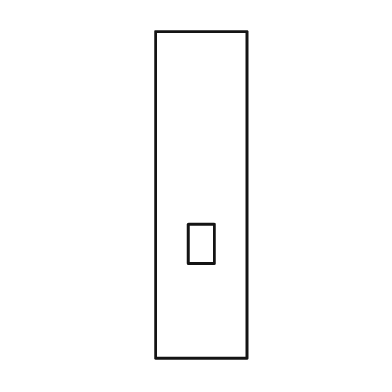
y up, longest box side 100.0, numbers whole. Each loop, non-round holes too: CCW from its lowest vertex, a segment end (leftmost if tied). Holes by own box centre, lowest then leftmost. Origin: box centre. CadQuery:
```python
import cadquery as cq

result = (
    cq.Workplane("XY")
    .moveTo(-14.0, -50.0)
    .lineTo(14.0, -50.0)
    .lineTo(14.0, 50.0)
    .lineTo(-14.0, 50.0)
    .close()
    .moveTo(-4.0, -21.0)
    .lineTo(4.0, -21.0)
    .lineTo(4.0, -9.0)
    .lineTo(-4.0, -9.0)
    .close()
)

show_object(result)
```